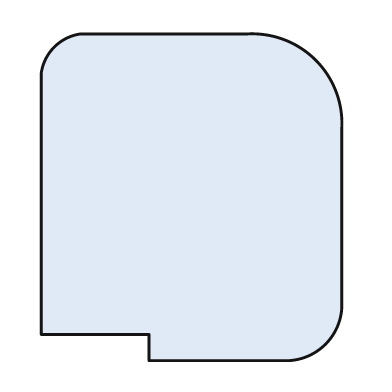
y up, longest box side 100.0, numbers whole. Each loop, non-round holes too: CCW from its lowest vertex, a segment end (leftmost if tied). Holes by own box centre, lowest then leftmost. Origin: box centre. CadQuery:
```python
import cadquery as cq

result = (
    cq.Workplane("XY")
    .moveTo(-13.0, -50.0)
    .lineTo(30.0, -50.0)
    .threePointArc((41.0, -45.0), (46.0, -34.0))
    .lineTo(46.0, 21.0)
    .threePointArc((38.0, 42.0), (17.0, 50.0))
    .lineTo(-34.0, 50.0)
    .threePointArc((-42.0, 46.0), (-46.0, 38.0))
    .lineTo(-46.0, -42.0)
    .lineTo(-13.0, -42.0)
    .close()
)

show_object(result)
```